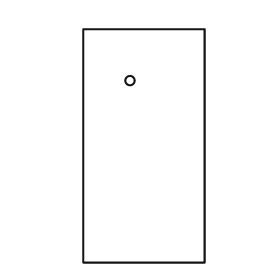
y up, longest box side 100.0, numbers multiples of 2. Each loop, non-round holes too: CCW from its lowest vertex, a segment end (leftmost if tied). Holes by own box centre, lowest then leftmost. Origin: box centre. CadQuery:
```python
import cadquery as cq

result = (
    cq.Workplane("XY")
    .moveTo(-26.0, -50.0)
    .lineTo(26.0, -50.0)
    .lineTo(26.0, 50.0)
    .lineTo(-26.0, 50.0)
    .close()
    .moveTo(-6.0, 28.0)
    .circle(2.0)
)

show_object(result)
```